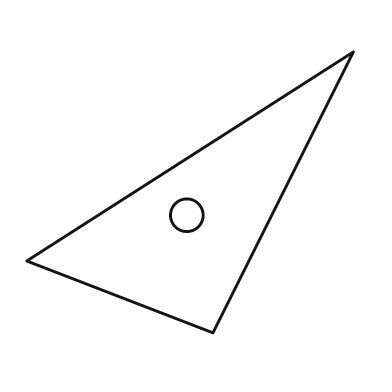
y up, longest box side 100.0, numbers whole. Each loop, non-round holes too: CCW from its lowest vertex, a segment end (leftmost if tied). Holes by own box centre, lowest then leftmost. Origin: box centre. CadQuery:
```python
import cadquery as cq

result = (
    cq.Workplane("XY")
    .moveTo(7.0, -43.0)
    .lineTo(50.0, 43.0)
    .lineTo(-50.0, -21.0)
    .close()
    .moveTo(-1.0, -7.0)
    .circle(5.0)
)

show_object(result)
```